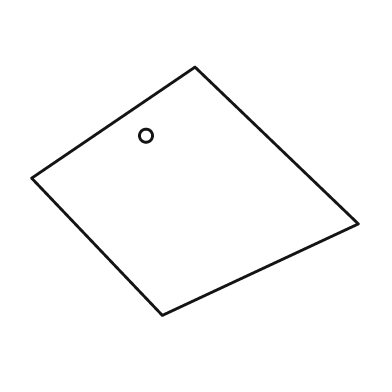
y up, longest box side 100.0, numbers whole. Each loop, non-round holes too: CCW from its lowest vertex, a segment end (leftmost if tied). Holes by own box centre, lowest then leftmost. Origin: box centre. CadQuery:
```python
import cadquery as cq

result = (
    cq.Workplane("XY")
    .moveTo(-10.0, -38.0)
    .lineTo(50.0, -10.0)
    .lineTo(0.0, 38.0)
    .lineTo(-50.0, 4.0)
    .close()
    .moveTo(-15.0, 17.0)
    .circle(2.0)
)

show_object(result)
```